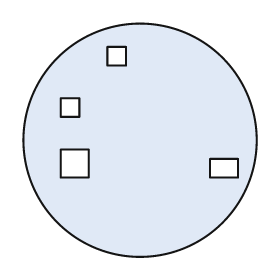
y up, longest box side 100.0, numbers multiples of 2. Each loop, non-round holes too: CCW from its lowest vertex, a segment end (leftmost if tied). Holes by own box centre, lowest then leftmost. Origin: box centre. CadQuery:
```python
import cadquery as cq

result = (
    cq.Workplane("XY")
    .moveTo(0.0, 0.0)
    .circle(50.0)
    .moveTo(30.0, -16.0)
    .lineTo(42.0, -16.0)
    .lineTo(42.0, -8.0)
    .lineTo(30.0, -8.0)
    .close()
    .moveTo(-34.0, -16.0)
    .lineTo(-22.0, -16.0)
    .lineTo(-22.0, -4.0)
    .lineTo(-34.0, -4.0)
    .close()
    .moveTo(-34.0, 10.0)
    .lineTo(-26.0, 10.0)
    .lineTo(-26.0, 18.0)
    .lineTo(-34.0, 18.0)
    .close()
    .moveTo(-14.0, 32.0)
    .lineTo(-6.0, 32.0)
    .lineTo(-6.0, 40.0)
    .lineTo(-14.0, 40.0)
    .close()
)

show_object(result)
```